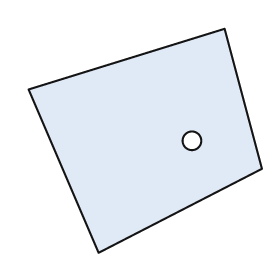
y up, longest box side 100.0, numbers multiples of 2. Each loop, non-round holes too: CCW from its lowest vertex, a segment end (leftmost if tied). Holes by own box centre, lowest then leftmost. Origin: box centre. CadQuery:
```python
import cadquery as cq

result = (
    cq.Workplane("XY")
    .moveTo(-20.0, -48.0)
    .lineTo(50.0, -12.0)
    .lineTo(34.0, 48.0)
    .lineTo(-50.0, 22.0)
    .close()
    .moveTo(20.0, 0.0)
    .circle(4.0)
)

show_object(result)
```